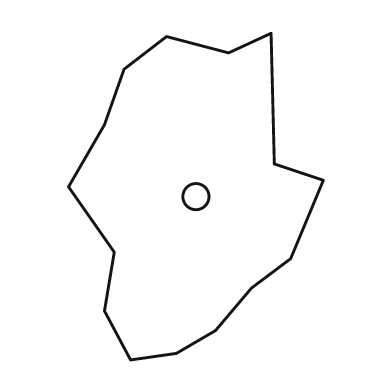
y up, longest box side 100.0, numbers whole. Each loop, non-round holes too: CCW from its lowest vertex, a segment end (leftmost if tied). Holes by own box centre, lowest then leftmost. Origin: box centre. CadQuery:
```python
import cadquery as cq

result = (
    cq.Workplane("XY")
    .moveTo(-20.0, -50.0)
    .lineTo(-6.0, -48.0)
    .lineTo(6.0, -41.0)
    .lineTo(17.0, -28.0)
    .lineTo(29.0, -19.0)
    .lineTo(39.0, 5.0)
    .lineTo(24.0, 10.0)
    .lineTo(23.0, 50.0)
    .lineTo(10.0, 44.0)
    .lineTo(-9.0, 49.0)
    .lineTo(-22.0, 39.0)
    .lineTo(-28.0, 22.0)
    .lineTo(-39.0, 3.0)
    .lineTo(-25.0, -17.0)
    .lineTo(-28.0, -35.0)
    .close()
    .moveTo(0.0, 0.0)
    .circle(4.0)
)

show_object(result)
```